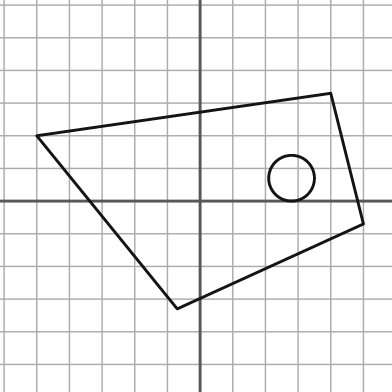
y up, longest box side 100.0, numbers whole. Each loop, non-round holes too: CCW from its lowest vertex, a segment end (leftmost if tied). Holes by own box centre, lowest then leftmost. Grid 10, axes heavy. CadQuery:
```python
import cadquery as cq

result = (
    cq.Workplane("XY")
    .moveTo(-7.0, -33.0)
    .lineTo(50.0, -7.0)
    .lineTo(40.0, 33.0)
    .lineTo(-50.0, 20.0)
    .close()
    .moveTo(28.0, 7.0)
    .circle(7.0)
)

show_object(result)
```